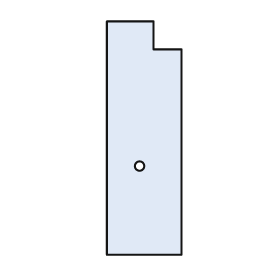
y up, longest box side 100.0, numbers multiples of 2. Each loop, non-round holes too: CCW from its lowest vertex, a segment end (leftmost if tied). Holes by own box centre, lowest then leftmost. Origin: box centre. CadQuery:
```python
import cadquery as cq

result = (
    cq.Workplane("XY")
    .moveTo(-16.0, -50.0)
    .lineTo(16.0, -50.0)
    .lineTo(16.0, 38.0)
    .lineTo(4.0, 38.0)
    .lineTo(4.0, 50.0)
    .lineTo(-16.0, 50.0)
    .close()
    .moveTo(-2.0, -12.0)
    .circle(2.0)
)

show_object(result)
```